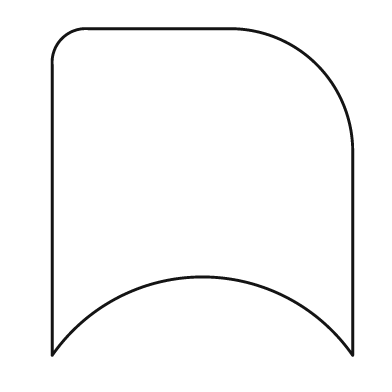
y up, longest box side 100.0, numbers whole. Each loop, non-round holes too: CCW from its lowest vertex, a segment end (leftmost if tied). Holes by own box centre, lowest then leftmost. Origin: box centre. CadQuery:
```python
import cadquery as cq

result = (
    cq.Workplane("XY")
    .moveTo(-46.0, -50.0)
    .threePointArc((0.0, -26.0), (46.0, -50.0))
    .lineTo(46.0, 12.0)
    .threePointArc((35.0, 39.0), (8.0, 50.0))
    .lineTo(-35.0, 50.0)
    .threePointArc((-43.0, 47.0), (-46.0, 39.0))
    .close()
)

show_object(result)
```